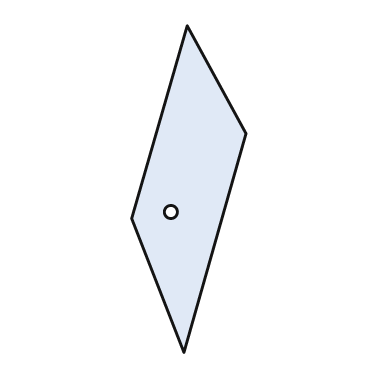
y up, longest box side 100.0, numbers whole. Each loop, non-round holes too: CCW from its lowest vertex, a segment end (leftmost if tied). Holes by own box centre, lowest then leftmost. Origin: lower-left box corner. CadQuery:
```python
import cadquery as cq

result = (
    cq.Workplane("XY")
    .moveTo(16.0, 0.0)
    .lineTo(35.0, 67.0)
    .lineTo(17.0, 100.0)
    .lineTo(0.0, 41.0)
    .close()
    .moveTo(12.0, 43.0)
    .circle(2.0)
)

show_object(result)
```